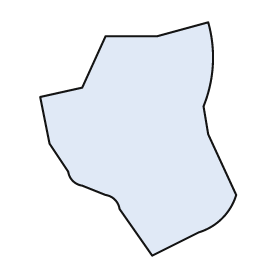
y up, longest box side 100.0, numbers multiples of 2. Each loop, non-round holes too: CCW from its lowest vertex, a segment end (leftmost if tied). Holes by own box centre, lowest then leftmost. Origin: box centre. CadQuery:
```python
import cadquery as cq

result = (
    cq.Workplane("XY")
    .moveTo(6.0, -50.0)
    .lineTo(26.0, -40.0)
    .threePointArc((36.0, -34.0), (42.0, -24.0))
    .lineTo(30.0, 2.0)
    .lineTo(28.0, 14.0)
    .threePointArc((32.0, 32.0), (30.0, 50.0))
    .lineTo(8.0, 44.0)
    .lineTo(-14.0, 44.0)
    .lineTo(-24.0, 22.0)
    .lineTo(-42.0, 18.0)
    .lineTo(-38.0, -2.0)
    .lineTo(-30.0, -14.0)
    .threePointArc((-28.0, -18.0), (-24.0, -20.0))
    .lineTo(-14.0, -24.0)
    .threePointArc((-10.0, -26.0), (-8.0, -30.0))
    .close()
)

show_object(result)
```